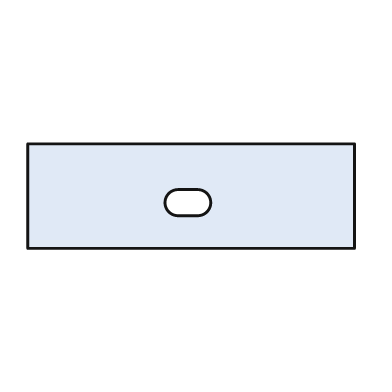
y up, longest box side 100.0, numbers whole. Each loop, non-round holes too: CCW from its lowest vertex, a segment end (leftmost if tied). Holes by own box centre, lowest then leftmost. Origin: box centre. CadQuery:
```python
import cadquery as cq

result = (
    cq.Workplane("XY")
    .moveTo(-50.0, -16.0)
    .lineTo(50.0, -16.0)
    .lineTo(50.0, 16.0)
    .lineTo(-50.0, 16.0)
    .close()
    .moveTo(-4.0, -6.0)
    .lineTo(2.0, -6.0)
    .threePointArc((6.0, -2.0), (2.0, 2.0))
    .lineTo(-4.0, 2.0)
    .threePointArc((-8.0, -2.0), (-4.0, -6.0))
    .close()
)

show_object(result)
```